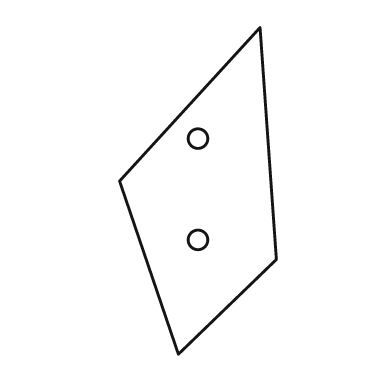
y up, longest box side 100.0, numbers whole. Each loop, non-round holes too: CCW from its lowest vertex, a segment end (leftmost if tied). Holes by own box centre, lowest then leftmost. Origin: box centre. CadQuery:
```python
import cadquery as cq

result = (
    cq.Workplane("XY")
    .moveTo(-6.0, -50.0)
    .lineTo(24.0, -21.0)
    .lineTo(19.0, 50.0)
    .lineTo(-24.0, 3.0)
    .close()
    .moveTo(0.0, -15.0)
    .circle(3.0)
    .moveTo(0.0, 16.0)
    .circle(3.0)
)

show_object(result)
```